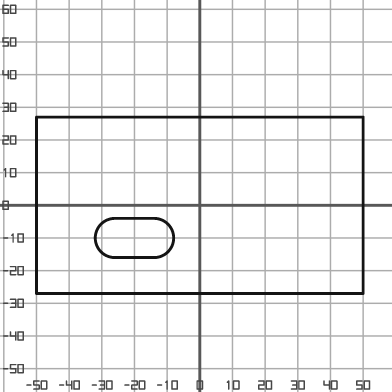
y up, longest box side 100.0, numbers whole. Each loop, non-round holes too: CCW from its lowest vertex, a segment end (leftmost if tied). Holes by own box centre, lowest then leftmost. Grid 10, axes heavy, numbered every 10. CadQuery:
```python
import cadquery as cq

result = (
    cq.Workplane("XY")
    .moveTo(-50.0, -27.0)
    .lineTo(50.0, -27.0)
    .lineTo(50.0, 27.0)
    .lineTo(-50.0, 27.0)
    .close()
    .moveTo(-26.0, -16.0)
    .lineTo(-14.0, -16.0)
    .threePointArc((-8.0, -10.0), (-14.0, -4.0))
    .lineTo(-26.0, -4.0)
    .threePointArc((-32.0, -10.0), (-26.0, -16.0))
    .close()
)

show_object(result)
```